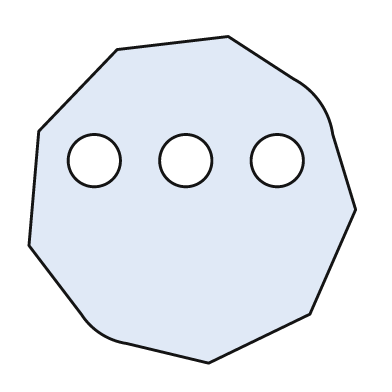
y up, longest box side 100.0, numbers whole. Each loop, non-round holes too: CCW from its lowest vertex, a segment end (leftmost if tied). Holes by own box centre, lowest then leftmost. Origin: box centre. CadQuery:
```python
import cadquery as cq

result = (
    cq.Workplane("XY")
    .moveTo(5.0, -50.0)
    .lineTo(36.0, -35.0)
    .lineTo(50.0, -3.0)
    .lineTo(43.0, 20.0)
    .threePointArc((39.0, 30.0), (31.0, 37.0))
    .lineTo(11.0, 50.0)
    .lineTo(-23.0, 46.0)
    .lineTo(-47.0, 21.0)
    .lineTo(-50.0, -14.0)
    .lineTo(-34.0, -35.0)
    .threePointArc((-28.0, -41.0), (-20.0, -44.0))
    .close()
    .moveTo(-30.0, 12.0)
    .circle(8.0)
    .moveTo(-2.0, 12.0)
    .circle(8.0)
    .moveTo(26.0, 12.0)
    .circle(8.0)
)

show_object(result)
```